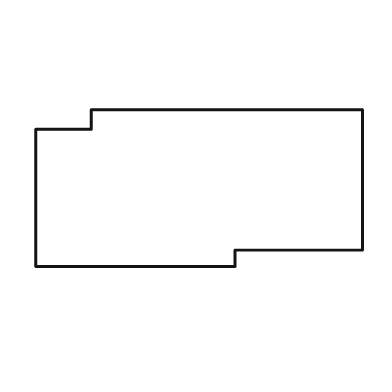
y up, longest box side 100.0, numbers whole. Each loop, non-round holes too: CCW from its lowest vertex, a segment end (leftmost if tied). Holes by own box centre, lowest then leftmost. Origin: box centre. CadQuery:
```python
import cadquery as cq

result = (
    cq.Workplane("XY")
    .moveTo(-50.0, -24.0)
    .lineTo(11.0, -24.0)
    .lineTo(11.0, -19.0)
    .lineTo(50.0, -19.0)
    .lineTo(50.0, 24.0)
    .lineTo(-33.0, 24.0)
    .lineTo(-33.0, 18.0)
    .lineTo(-50.0, 18.0)
    .close()
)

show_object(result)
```